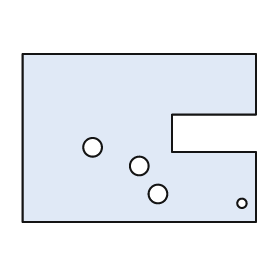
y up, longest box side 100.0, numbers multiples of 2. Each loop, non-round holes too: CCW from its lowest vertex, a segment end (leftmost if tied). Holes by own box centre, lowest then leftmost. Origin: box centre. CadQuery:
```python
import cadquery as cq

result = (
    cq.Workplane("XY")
    .moveTo(-50.0, -36.0)
    .lineTo(50.0, -36.0)
    .lineTo(50.0, -6.0)
    .lineTo(14.0, -6.0)
    .lineTo(14.0, 10.0)
    .lineTo(50.0, 10.0)
    .lineTo(50.0, 36.0)
    .lineTo(-50.0, 36.0)
    .close()
    .moveTo(44.0, -28.0)
    .circle(2.0)
    .moveTo(8.0, -24.0)
    .circle(4.0)
    .moveTo(0.0, -12.0)
    .circle(4.0)
    .moveTo(-20.0, -4.0)
    .circle(4.0)
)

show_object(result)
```